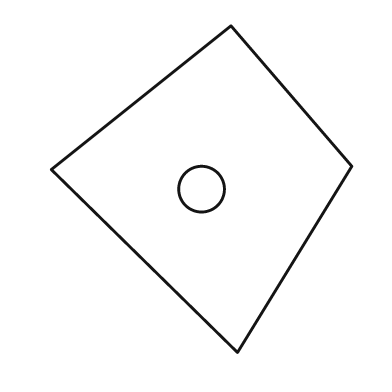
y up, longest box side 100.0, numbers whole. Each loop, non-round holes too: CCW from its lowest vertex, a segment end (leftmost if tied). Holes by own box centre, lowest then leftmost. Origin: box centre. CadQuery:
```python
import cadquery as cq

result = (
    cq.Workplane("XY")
    .moveTo(11.0, -50.0)
    .lineTo(46.0, 7.0)
    .lineTo(9.0, 50.0)
    .lineTo(-46.0, 6.0)
    .close()
    .moveTo(0.0, 0.0)
    .circle(7.0)
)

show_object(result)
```